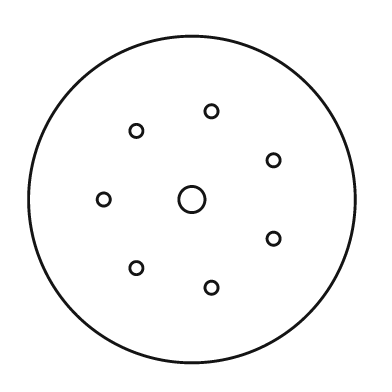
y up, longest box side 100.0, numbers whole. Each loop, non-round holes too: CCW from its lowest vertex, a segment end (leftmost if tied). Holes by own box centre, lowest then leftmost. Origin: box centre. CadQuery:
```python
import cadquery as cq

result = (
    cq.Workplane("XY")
    .moveTo(0.0, 0.0)
    .circle(50.0)
    .moveTo(6.0, -27.0)
    .circle(2.0)
    .moveTo(-17.0, -21.0)
    .circle(2.0)
    .moveTo(25.0, -12.0)
    .circle(2.0)
    .moveTo(-27.0, 0.0)
    .circle(2.0)
    .moveTo(0.0, 0.0)
    .circle(4.0)
    .moveTo(25.0, 12.0)
    .circle(2.0)
    .moveTo(-17.0, 21.0)
    .circle(2.0)
    .moveTo(6.0, 27.0)
    .circle(2.0)
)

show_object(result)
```